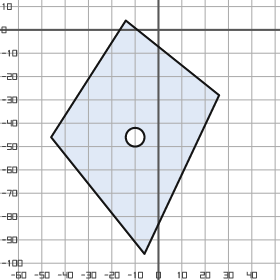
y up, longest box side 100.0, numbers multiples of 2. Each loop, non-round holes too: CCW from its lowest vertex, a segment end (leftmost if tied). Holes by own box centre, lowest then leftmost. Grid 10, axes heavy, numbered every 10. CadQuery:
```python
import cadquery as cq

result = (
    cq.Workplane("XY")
    .moveTo(-6.0, -96.0)
    .lineTo(26.0, -28.0)
    .lineTo(-14.0, 4.0)
    .lineTo(-46.0, -46.0)
    .close()
    .moveTo(-10.0, -46.0)
    .circle(4.0)
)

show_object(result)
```